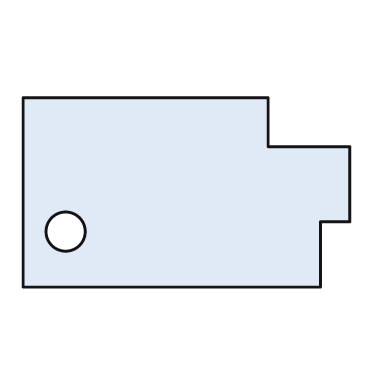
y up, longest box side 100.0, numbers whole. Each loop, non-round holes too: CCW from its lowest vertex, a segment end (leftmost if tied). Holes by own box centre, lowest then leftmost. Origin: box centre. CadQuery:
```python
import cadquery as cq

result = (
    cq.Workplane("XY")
    .moveTo(-50.0, -29.0)
    .lineTo(41.0, -29.0)
    .lineTo(41.0, -9.0)
    .lineTo(50.0, -9.0)
    .lineTo(50.0, 14.0)
    .lineTo(25.0, 14.0)
    .lineTo(25.0, 29.0)
    .lineTo(-50.0, 29.0)
    .close()
    .moveTo(-37.0, -12.0)
    .circle(6.0)
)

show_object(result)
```